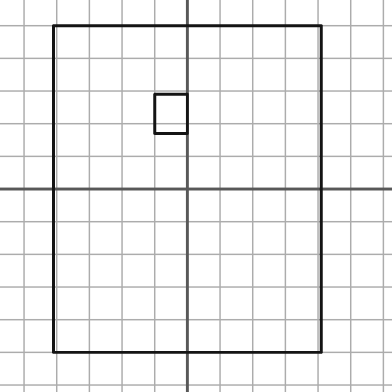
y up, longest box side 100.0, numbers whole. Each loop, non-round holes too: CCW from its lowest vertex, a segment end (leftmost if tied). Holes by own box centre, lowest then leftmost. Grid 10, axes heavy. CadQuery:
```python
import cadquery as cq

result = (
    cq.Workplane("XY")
    .moveTo(-41.0, -50.0)
    .lineTo(41.0, -50.0)
    .lineTo(41.0, 50.0)
    .lineTo(-41.0, 50.0)
    .close()
    .moveTo(-10.0, 17.0)
    .lineTo(0.0, 17.0)
    .lineTo(0.0, 29.0)
    .lineTo(-10.0, 29.0)
    .close()
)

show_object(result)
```